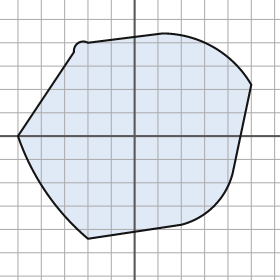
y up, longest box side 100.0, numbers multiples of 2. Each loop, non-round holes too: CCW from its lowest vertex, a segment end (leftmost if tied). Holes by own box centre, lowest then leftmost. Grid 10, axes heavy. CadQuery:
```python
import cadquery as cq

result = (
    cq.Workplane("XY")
    .moveTo(-20.0, -44.0)
    .lineTo(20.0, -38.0)
    .threePointArc((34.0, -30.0), (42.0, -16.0))
    .lineTo(50.0, 22.0)
    .threePointArc((34.0, 38.0), (12.0, 44.0))
    .lineTo(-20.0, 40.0)
    .threePointArc((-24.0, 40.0), (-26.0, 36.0))
    .lineTo(-50.0, 0.0)
    .threePointArc((-38.0, -24.0), (-20.0, -44.0))
    .close()
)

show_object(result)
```